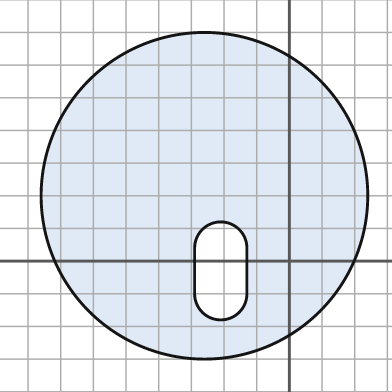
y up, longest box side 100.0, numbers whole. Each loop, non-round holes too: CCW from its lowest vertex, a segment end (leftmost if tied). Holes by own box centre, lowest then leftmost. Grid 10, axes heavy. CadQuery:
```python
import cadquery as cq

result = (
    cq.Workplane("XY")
    .moveTo(-26.0, 20.0)
    .circle(50.0)
    .moveTo(-29.0, -10.0)
    .threePointArc((-21.0, -18.0), (-13.0, -10.0))
    .lineTo(-13.0, 4.0)
    .threePointArc((-21.0, 12.0), (-29.0, 4.0))
    .close()
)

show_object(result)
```